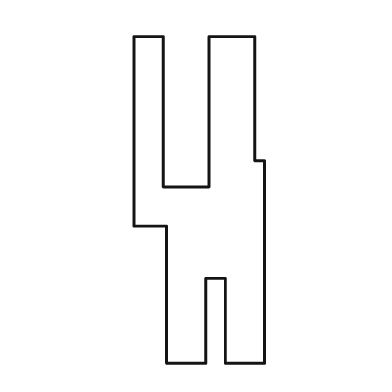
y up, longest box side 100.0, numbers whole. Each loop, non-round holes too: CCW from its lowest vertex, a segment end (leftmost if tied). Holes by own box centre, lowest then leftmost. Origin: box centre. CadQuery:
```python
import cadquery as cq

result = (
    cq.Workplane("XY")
    .moveTo(-10.0, -50.0)
    .lineTo(2.0, -50.0)
    .lineTo(2.0, -24.0)
    .lineTo(8.0, -24.0)
    .lineTo(8.0, -50.0)
    .lineTo(20.0, -50.0)
    .lineTo(20.0, 12.0)
    .lineTo(17.0, 12.0)
    .lineTo(17.0, 50.0)
    .lineTo(3.0, 50.0)
    .lineTo(3.0, 4.0)
    .lineTo(-11.0, 4.0)
    .lineTo(-11.0, 50.0)
    .lineTo(-20.0, 50.0)
    .lineTo(-20.0, -8.0)
    .lineTo(-10.0, -8.0)
    .close()
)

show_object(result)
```